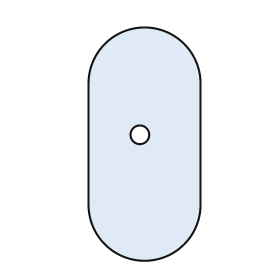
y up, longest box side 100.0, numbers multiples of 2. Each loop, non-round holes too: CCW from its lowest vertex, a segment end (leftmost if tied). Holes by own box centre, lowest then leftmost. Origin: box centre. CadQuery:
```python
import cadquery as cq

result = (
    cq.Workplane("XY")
    .moveTo(-24.0, -26.0)
    .threePointArc((0.0, -50.0), (24.0, -26.0))
    .lineTo(24.0, 26.0)
    .threePointArc((0.0, 50.0), (-24.0, 26.0))
    .close()
    .moveTo(-2.0, 4.0)
    .circle(4.0)
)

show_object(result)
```